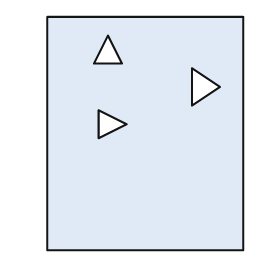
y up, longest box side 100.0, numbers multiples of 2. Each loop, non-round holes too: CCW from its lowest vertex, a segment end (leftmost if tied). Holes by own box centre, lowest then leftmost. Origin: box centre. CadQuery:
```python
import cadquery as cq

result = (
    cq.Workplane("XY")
    .moveTo(-42.0, -50.0)
    .lineTo(42.0, -50.0)
    .lineTo(42.0, 50.0)
    .lineTo(-42.0, 50.0)
    .close()
    .moveTo(-20.0, -2.0)
    .lineTo(-8.0, 4.0)
    .lineTo(-20.0, 10.0)
    .close()
    .moveTo(20.0, 12.0)
    .lineTo(32.0, 20.0)
    .lineTo(20.0, 28.0)
    .close()
    .moveTo(-22.0, 30.0)
    .lineTo(-10.0, 30.0)
    .lineTo(-16.0, 42.0)
    .close()
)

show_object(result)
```